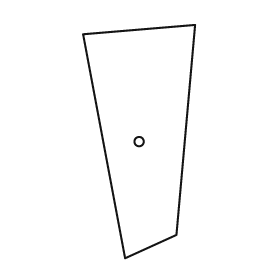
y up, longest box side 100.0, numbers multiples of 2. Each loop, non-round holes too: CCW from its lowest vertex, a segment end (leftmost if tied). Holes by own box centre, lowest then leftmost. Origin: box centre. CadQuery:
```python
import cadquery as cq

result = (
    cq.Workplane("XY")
    .moveTo(-6.0, -50.0)
    .lineTo(16.0, -40.0)
    .lineTo(24.0, 50.0)
    .lineTo(-24.0, 46.0)
    .close()
    .moveTo(0.0, 0.0)
    .circle(2.0)
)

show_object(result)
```